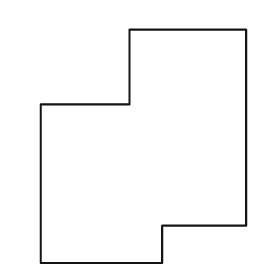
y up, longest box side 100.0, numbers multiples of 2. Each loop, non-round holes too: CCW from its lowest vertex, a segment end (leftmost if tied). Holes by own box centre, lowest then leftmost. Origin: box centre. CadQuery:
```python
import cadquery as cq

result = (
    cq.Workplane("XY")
    .moveTo(-44.0, -50.0)
    .lineTo(8.0, -50.0)
    .lineTo(8.0, -34.0)
    .lineTo(44.0, -34.0)
    .lineTo(44.0, 50.0)
    .lineTo(-6.0, 50.0)
    .lineTo(-6.0, 18.0)
    .lineTo(-44.0, 18.0)
    .close()
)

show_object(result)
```